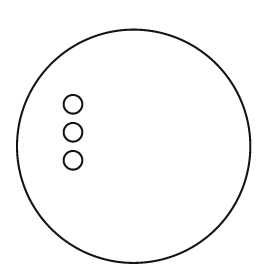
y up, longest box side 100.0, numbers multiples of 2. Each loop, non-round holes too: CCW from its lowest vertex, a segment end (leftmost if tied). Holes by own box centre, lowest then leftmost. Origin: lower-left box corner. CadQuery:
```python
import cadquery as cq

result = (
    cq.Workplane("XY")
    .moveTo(50.0, 50.0)
    .circle(50.0)
    .moveTo(24.0, 44.0)
    .circle(4.0)
    .moveTo(24.0, 56.0)
    .circle(4.0)
    .moveTo(24.0, 68.0)
    .circle(4.0)
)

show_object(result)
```